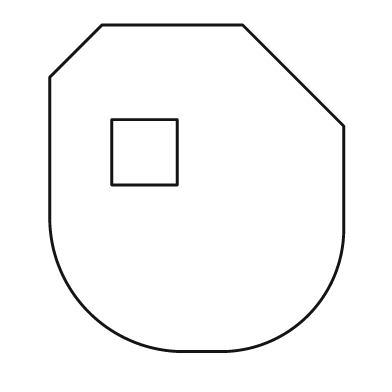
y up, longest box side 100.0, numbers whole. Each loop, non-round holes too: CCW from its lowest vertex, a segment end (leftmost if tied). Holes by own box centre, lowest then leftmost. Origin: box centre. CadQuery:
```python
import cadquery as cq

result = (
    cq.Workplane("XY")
    .moveTo(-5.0, -50.0)
    .lineTo(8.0, -50.0)
    .threePointArc((34.0, -39.0), (45.0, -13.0))
    .lineTo(45.0, 19.0)
    .lineTo(14.0, 50.0)
    .lineTo(-29.0, 50.0)
    .lineTo(-45.0, 34.0)
    .lineTo(-45.0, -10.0)
    .threePointArc((-33.0, -38.0), (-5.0, -50.0))
    .close()
    .moveTo(-26.0, 1.0)
    .lineTo(-6.0, 1.0)
    .lineTo(-6.0, 21.0)
    .lineTo(-26.0, 21.0)
    .close()
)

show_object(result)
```